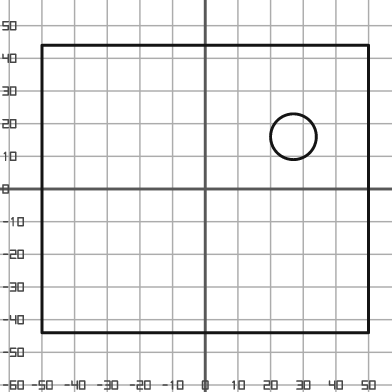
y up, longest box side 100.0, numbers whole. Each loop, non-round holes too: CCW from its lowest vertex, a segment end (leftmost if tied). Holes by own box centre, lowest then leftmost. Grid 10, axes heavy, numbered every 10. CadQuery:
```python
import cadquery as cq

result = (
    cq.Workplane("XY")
    .moveTo(-50.0, -44.0)
    .lineTo(50.0, -44.0)
    .lineTo(50.0, 44.0)
    .lineTo(-50.0, 44.0)
    .close()
    .moveTo(27.0, 16.0)
    .circle(7.0)
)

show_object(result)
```